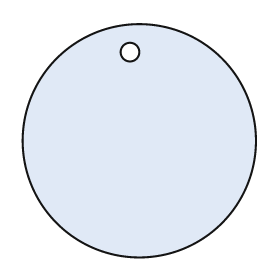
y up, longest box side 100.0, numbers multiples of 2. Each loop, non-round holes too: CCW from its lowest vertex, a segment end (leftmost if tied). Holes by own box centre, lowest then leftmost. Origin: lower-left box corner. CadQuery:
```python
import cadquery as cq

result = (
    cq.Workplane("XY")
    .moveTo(50.0, 50.0)
    .circle(50.0)
    .moveTo(46.0, 88.0)
    .circle(4.0)
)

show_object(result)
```